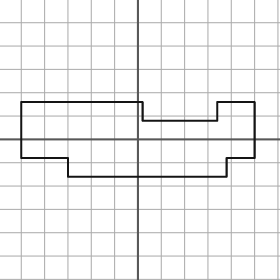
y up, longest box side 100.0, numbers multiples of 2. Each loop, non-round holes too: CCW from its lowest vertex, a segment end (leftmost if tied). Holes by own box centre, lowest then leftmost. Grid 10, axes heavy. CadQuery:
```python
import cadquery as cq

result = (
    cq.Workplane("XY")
    .moveTo(-30.0, -16.0)
    .lineTo(38.0, -16.0)
    .lineTo(38.0, -8.0)
    .lineTo(50.0, -8.0)
    .lineTo(50.0, 16.0)
    .lineTo(34.0, 16.0)
    .lineTo(34.0, 8.0)
    .lineTo(2.0, 8.0)
    .lineTo(2.0, 16.0)
    .lineTo(-50.0, 16.0)
    .lineTo(-50.0, -8.0)
    .lineTo(-30.0, -8.0)
    .close()
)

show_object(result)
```